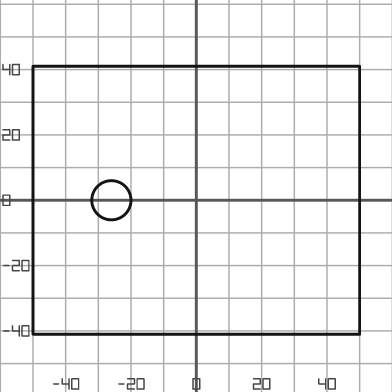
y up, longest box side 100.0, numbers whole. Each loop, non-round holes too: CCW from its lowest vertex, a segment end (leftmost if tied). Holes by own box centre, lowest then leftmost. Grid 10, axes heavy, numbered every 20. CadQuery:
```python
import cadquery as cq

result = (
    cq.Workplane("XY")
    .moveTo(-50.0, -41.0)
    .lineTo(50.0, -41.0)
    .lineTo(50.0, 41.0)
    .lineTo(-50.0, 41.0)
    .close()
    .moveTo(-26.0, 0.0)
    .circle(6.0)
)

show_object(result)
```